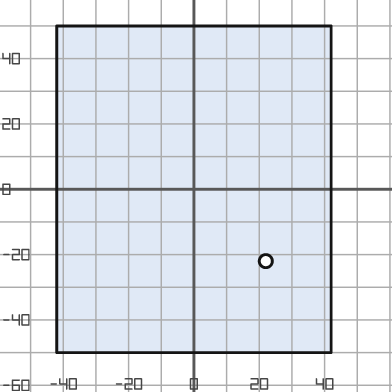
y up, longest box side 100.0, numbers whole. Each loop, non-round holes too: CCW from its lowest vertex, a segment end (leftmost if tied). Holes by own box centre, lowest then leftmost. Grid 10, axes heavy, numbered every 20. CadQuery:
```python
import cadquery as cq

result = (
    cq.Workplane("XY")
    .moveTo(-42.0, -50.0)
    .lineTo(42.0, -50.0)
    .lineTo(42.0, 50.0)
    .lineTo(-42.0, 50.0)
    .close()
    .moveTo(22.0, -22.0)
    .circle(2.0)
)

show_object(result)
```